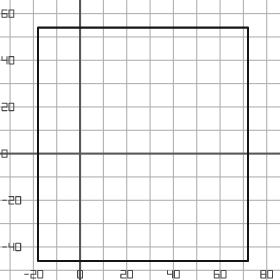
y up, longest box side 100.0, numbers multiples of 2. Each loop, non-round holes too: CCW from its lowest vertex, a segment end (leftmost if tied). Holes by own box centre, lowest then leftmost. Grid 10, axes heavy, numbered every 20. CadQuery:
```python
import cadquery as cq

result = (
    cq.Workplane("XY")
    .moveTo(-18.0, -46.0)
    .lineTo(72.0, -46.0)
    .lineTo(72.0, 54.0)
    .lineTo(-18.0, 54.0)
    .close()
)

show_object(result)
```